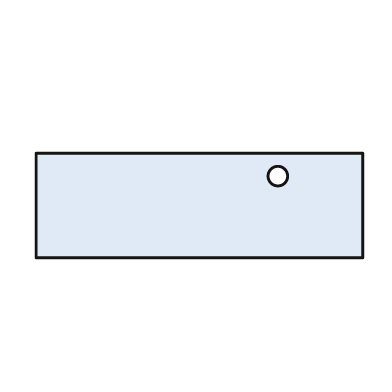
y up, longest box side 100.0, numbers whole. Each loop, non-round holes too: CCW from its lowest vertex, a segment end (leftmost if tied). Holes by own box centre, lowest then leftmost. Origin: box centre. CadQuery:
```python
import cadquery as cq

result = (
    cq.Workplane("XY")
    .moveTo(-50.0, -16.0)
    .lineTo(50.0, -16.0)
    .lineTo(50.0, 16.0)
    .lineTo(-50.0, 16.0)
    .close()
    .moveTo(24.0, 9.0)
    .circle(3.0)
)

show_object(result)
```